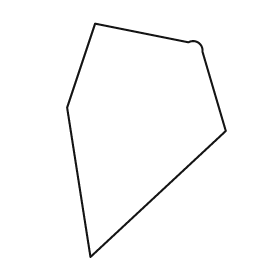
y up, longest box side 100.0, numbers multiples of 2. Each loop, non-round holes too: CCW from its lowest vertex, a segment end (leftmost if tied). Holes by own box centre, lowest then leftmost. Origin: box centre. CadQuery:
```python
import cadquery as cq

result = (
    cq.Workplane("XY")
    .moveTo(-24.0, -50.0)
    .lineTo(34.0, 4.0)
    .lineTo(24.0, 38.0)
    .threePointArc((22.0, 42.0), (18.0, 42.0))
    .lineTo(-22.0, 50.0)
    .lineTo(-34.0, 14.0)
    .close()
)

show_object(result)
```